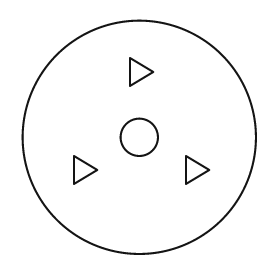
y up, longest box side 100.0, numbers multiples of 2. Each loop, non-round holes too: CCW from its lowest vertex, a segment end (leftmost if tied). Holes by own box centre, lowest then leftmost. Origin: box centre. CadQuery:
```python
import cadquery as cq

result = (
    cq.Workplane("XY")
    .moveTo(0.0, 0.0)
    .circle(50.0)
    .moveTo(-28.0, -20.0)
    .lineTo(-18.0, -14.0)
    .lineTo(-28.0, -8.0)
    .close()
    .moveTo(20.0, -20.0)
    .lineTo(30.0, -14.0)
    .lineTo(20.0, -8.0)
    .close()
    .moveTo(0.0, 0.0)
    .circle(8.0)
    .moveTo(-4.0, 22.0)
    .lineTo(6.0, 28.0)
    .lineTo(-4.0, 34.0)
    .close()
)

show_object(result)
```